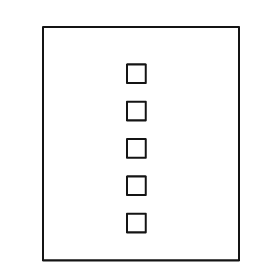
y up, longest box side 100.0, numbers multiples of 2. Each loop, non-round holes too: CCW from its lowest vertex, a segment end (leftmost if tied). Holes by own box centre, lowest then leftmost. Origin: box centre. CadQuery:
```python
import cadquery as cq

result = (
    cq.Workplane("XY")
    .moveTo(-42.0, -50.0)
    .lineTo(42.0, -50.0)
    .lineTo(42.0, 50.0)
    .lineTo(-42.0, 50.0)
    .close()
    .moveTo(-6.0, -38.0)
    .lineTo(2.0, -38.0)
    .lineTo(2.0, -30.0)
    .lineTo(-6.0, -30.0)
    .close()
    .moveTo(-6.0, -22.0)
    .lineTo(2.0, -22.0)
    .lineTo(2.0, -14.0)
    .lineTo(-6.0, -14.0)
    .close()
    .moveTo(-6.0, -6.0)
    .lineTo(2.0, -6.0)
    .lineTo(2.0, 2.0)
    .lineTo(-6.0, 2.0)
    .close()
    .moveTo(-6.0, 10.0)
    .lineTo(2.0, 10.0)
    .lineTo(2.0, 18.0)
    .lineTo(-6.0, 18.0)
    .close()
    .moveTo(-6.0, 26.0)
    .lineTo(2.0, 26.0)
    .lineTo(2.0, 34.0)
    .lineTo(-6.0, 34.0)
    .close()
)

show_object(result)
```